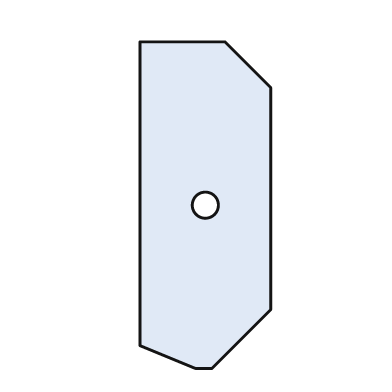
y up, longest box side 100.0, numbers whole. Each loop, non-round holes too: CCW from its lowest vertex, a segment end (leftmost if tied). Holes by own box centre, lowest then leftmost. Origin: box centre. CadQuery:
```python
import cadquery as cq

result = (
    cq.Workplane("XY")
    .moveTo(-3.0, -50.0)
    .lineTo(2.0, -50.0)
    .lineTo(20.0, -32.0)
    .lineTo(20.0, 36.0)
    .lineTo(6.0, 50.0)
    .lineTo(-20.0, 50.0)
    .lineTo(-20.0, -43.0)
    .close()
    .moveTo(0.0, 0.0)
    .circle(4.0)
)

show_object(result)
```